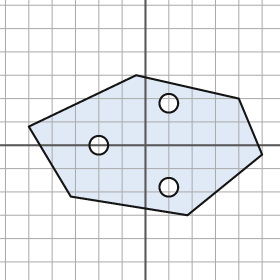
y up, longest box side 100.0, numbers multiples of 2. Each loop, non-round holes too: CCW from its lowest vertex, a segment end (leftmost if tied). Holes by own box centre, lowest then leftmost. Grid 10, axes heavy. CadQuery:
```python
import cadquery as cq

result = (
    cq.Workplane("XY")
    .moveTo(18.0, -30.0)
    .lineTo(50.0, -4.0)
    .lineTo(40.0, 20.0)
    .lineTo(-4.0, 30.0)
    .lineTo(-50.0, 8.0)
    .lineTo(-32.0, -22.0)
    .close()
    .moveTo(10.0, -18.0)
    .circle(4.0)
    .moveTo(-20.0, 0.0)
    .circle(4.0)
    .moveTo(10.0, 18.0)
    .circle(4.0)
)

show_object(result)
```